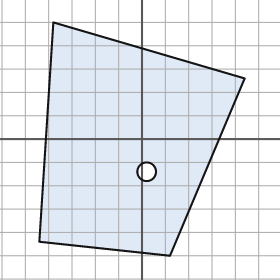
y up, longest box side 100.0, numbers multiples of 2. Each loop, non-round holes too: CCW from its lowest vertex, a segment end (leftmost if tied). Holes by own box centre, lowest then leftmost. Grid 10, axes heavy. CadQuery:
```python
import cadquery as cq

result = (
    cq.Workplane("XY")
    .moveTo(12.0, -50.0)
    .lineTo(44.0, 26.0)
    .lineTo(-38.0, 50.0)
    .lineTo(-44.0, -44.0)
    .close()
    .moveTo(2.0, -14.0)
    .circle(4.0)
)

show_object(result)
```